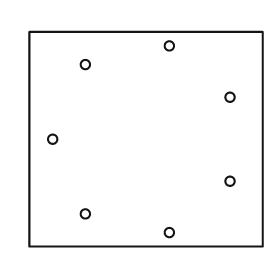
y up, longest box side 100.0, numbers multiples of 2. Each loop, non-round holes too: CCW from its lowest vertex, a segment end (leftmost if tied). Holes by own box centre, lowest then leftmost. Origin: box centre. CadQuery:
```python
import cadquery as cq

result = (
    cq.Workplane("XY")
    .moveTo(-50.0, -46.0)
    .lineTo(50.0, -46.0)
    .lineTo(50.0, 46.0)
    .lineTo(-50.0, 46.0)
    .close()
    .moveTo(10.0, -40.0)
    .circle(2.0)
    .moveTo(-26.0, -32.0)
    .circle(2.0)
    .moveTo(36.0, -18.0)
    .circle(2.0)
    .moveTo(-40.0, 0.0)
    .circle(2.0)
    .moveTo(36.0, 18.0)
    .circle(2.0)
    .moveTo(-26.0, 32.0)
    .circle(2.0)
    .moveTo(10.0, 40.0)
    .circle(2.0)
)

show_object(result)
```